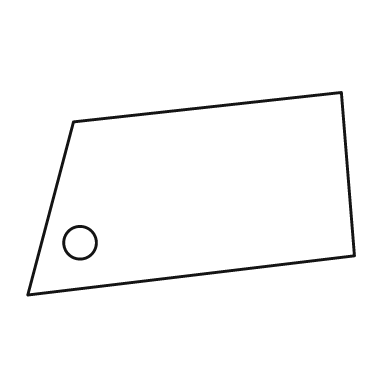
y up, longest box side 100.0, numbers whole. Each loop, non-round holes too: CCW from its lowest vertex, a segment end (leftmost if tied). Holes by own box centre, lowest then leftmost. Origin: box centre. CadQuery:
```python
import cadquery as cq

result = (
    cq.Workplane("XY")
    .moveTo(-50.0, -31.0)
    .lineTo(50.0, -19.0)
    .lineTo(46.0, 31.0)
    .lineTo(-36.0, 22.0)
    .close()
    .moveTo(-34.0, -15.0)
    .circle(5.0)
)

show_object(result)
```